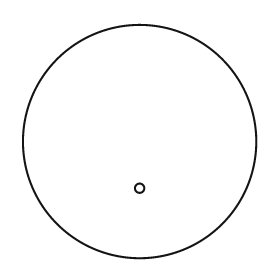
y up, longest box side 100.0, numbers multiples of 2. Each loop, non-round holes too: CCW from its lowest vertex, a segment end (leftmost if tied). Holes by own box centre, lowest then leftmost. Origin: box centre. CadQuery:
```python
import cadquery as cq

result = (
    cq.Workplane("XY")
    .moveTo(0.0, 0.0)
    .circle(50.0)
    .moveTo(0.0, -20.0)
    .circle(2.0)
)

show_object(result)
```